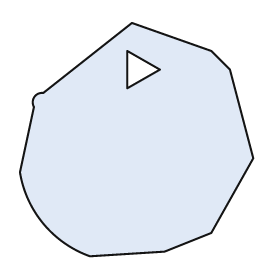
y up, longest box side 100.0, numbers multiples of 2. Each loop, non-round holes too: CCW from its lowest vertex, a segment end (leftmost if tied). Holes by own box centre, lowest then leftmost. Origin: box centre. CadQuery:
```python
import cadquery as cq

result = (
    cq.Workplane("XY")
    .moveTo(-20.0, -50.0)
    .lineTo(12.0, -48.0)
    .lineTo(32.0, -40.0)
    .lineTo(50.0, -8.0)
    .lineTo(40.0, 30.0)
    .lineTo(32.0, 38.0)
    .lineTo(-2.0, 50.0)
    .lineTo(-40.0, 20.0)
    .threePointArc((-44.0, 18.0), (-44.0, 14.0))
    .lineTo(-50.0, -14.0)
    .threePointArc((-40.0, -36.0), (-20.0, -50.0))
    .close()
    .moveTo(-4.0, 22.0)
    .lineTo(10.0, 30.0)
    .lineTo(-4.0, 38.0)
    .close()
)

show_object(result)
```